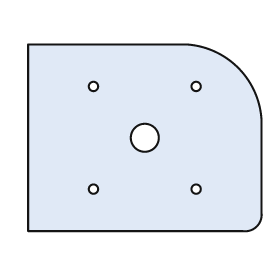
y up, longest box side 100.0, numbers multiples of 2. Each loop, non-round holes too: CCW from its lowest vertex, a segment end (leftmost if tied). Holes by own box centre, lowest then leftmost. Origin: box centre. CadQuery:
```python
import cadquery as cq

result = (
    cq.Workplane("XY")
    .moveTo(-50.0, -40.0)
    .lineTo(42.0, -40.0)
    .threePointArc((48.0, -38.0), (50.0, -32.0))
    .lineTo(50.0, 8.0)
    .threePointArc((40.0, 30.0), (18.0, 40.0))
    .lineTo(-50.0, 40.0)
    .close()
    .moveTo(-22.0, -22.0)
    .circle(2.0)
    .moveTo(22.0, -22.0)
    .circle(2.0)
    .moveTo(0.0, 0.0)
    .circle(6.0)
    .moveTo(-22.0, 22.0)
    .circle(2.0)
    .moveTo(22.0, 22.0)
    .circle(2.0)
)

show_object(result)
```